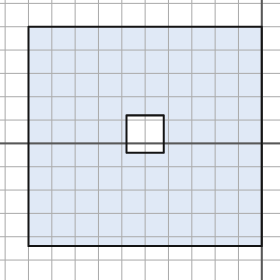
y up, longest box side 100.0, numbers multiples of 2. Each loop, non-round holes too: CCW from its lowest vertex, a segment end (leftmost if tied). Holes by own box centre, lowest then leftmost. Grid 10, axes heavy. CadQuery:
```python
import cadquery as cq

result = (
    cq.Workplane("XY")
    .moveTo(-100.0, -44.0)
    .lineTo(0.0, -44.0)
    .lineTo(0.0, 50.0)
    .lineTo(-100.0, 50.0)
    .close()
    .moveTo(-58.0, -4.0)
    .lineTo(-42.0, -4.0)
    .lineTo(-42.0, 12.0)
    .lineTo(-58.0, 12.0)
    .close()
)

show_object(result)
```